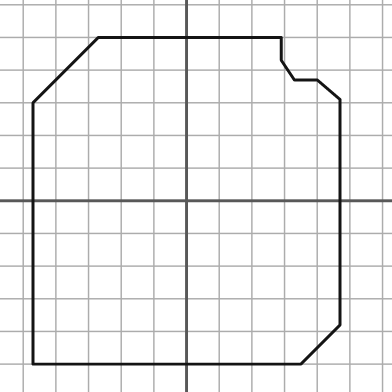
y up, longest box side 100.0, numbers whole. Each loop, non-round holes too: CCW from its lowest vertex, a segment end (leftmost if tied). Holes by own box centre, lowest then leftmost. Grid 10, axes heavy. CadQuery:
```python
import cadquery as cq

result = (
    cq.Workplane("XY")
    .moveTo(-47.0, -50.0)
    .lineTo(35.0, -50.0)
    .lineTo(47.0, -38.0)
    .lineTo(47.0, 31.0)
    .lineTo(40.0, 37.0)
    .lineTo(33.0, 37.0)
    .lineTo(29.0, 43.0)
    .lineTo(29.0, 50.0)
    .lineTo(-27.0, 50.0)
    .lineTo(-47.0, 30.0)
    .close()
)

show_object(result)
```